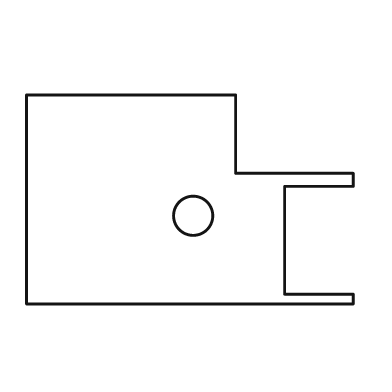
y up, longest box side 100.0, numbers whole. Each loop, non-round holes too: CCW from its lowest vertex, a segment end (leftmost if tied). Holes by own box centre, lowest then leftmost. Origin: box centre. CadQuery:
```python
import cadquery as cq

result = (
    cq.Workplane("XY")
    .moveTo(-50.0, -32.0)
    .lineTo(50.0, -32.0)
    .lineTo(50.0, -29.0)
    .lineTo(29.0, -29.0)
    .lineTo(29.0, 4.0)
    .lineTo(50.0, 4.0)
    .lineTo(50.0, 8.0)
    .lineTo(14.0, 8.0)
    .lineTo(14.0, 32.0)
    .lineTo(-50.0, 32.0)
    .close()
    .moveTo(1.0, -5.0)
    .circle(6.0)
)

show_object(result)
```